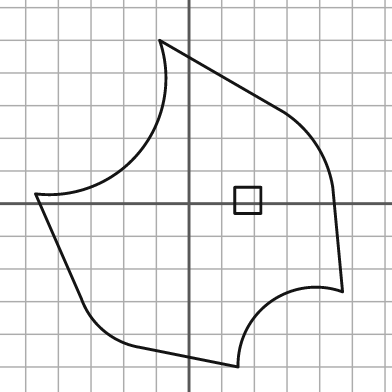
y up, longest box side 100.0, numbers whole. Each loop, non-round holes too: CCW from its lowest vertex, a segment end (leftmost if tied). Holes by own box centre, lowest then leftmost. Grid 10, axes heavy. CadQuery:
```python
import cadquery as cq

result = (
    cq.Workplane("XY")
    .moveTo(15.0, -50.0)
    .threePointArc((25.0, -30.0), (47.0, -27.0))
    .lineTo(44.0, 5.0)
    .threePointArc((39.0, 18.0), (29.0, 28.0))
    .lineTo(-9.0, 50.0)
    .threePointArc((-15.0, 16.0), (-47.0, 3.0))
    .lineTo(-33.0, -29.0)
    .threePointArc((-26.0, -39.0), (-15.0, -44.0))
    .close()
    .moveTo(14.0, -3.0)
    .lineTo(22.0, -3.0)
    .lineTo(22.0, 5.0)
    .lineTo(14.0, 5.0)
    .close()
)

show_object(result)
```